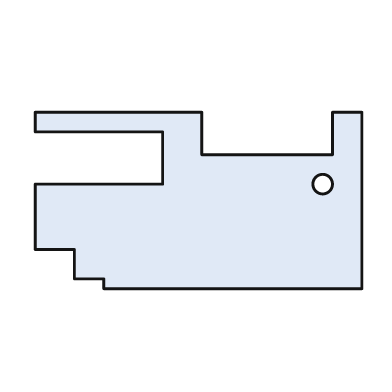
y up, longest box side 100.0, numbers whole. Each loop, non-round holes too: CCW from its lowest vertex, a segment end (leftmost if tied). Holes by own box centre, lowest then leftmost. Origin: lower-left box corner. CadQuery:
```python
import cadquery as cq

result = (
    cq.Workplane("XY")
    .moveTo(21.0, 0.0)
    .lineTo(100.0, 0.0)
    .lineTo(100.0, 54.0)
    .lineTo(91.0, 54.0)
    .lineTo(91.0, 41.0)
    .lineTo(51.0, 41.0)
    .lineTo(51.0, 54.0)
    .lineTo(0.0, 54.0)
    .lineTo(0.0, 48.0)
    .lineTo(39.0, 48.0)
    .lineTo(39.0, 32.0)
    .lineTo(0.0, 32.0)
    .lineTo(0.0, 12.0)
    .lineTo(12.0, 12.0)
    .lineTo(12.0, 3.0)
    .lineTo(21.0, 3.0)
    .close()
    .moveTo(88.0, 32.0)
    .circle(3.0)
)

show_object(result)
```